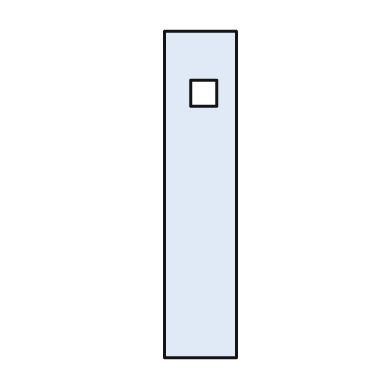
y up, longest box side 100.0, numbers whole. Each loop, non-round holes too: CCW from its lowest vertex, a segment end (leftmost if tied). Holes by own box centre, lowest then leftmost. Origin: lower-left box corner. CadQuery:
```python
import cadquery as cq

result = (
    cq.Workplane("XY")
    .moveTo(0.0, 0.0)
    .lineTo(22.0, 0.0)
    .lineTo(22.0, 100.0)
    .lineTo(0.0, 100.0)
    .close()
    .moveTo(8.0, 77.0)
    .lineTo(16.0, 77.0)
    .lineTo(16.0, 85.0)
    .lineTo(8.0, 85.0)
    .close()
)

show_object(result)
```